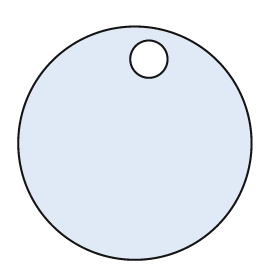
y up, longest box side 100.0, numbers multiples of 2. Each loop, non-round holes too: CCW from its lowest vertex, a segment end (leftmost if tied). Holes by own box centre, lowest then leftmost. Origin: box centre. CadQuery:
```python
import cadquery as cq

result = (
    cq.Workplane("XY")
    .moveTo(0.0, 0.0)
    .circle(50.0)
    .moveTo(6.0, 36.0)
    .circle(8.0)
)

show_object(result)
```